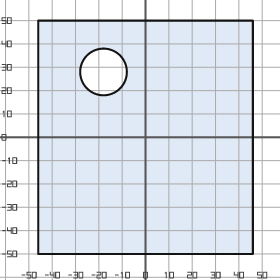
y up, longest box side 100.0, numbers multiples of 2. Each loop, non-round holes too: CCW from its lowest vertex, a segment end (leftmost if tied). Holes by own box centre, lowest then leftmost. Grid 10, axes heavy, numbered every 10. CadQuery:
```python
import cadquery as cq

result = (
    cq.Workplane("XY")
    .moveTo(-46.0, -50.0)
    .lineTo(46.0, -50.0)
    .lineTo(46.0, 50.0)
    .lineTo(-46.0, 50.0)
    .close()
    .moveTo(-18.0, 28.0)
    .circle(10.0)
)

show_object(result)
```